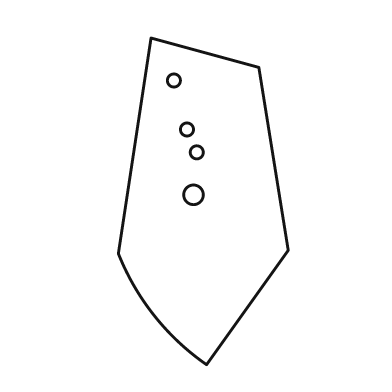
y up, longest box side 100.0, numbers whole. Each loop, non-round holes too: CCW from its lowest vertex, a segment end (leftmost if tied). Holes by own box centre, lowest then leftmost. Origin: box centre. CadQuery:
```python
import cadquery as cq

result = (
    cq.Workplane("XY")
    .moveTo(1.0, -50.0)
    .lineTo(26.0, -15.0)
    .lineTo(17.0, 41.0)
    .lineTo(-16.0, 50.0)
    .lineTo(-26.0, -16.0)
    .threePointArc((-15.0, -35.0), (1.0, -50.0))
    .close()
    .moveTo(-3.0, 2.0)
    .circle(3.0)
    .moveTo(-2.0, 15.0)
    .circle(2.0)
    .moveTo(-5.0, 22.0)
    .circle(2.0)
    .moveTo(-9.0, 37.0)
    .circle(2.0)
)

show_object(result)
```